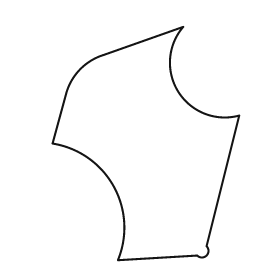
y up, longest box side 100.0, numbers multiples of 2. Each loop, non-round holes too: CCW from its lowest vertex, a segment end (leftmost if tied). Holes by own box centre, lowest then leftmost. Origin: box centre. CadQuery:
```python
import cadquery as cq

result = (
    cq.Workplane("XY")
    .moveTo(-12.0, -50.0)
    .lineTo(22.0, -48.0)
    .threePointArc((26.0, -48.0), (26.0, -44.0))
    .lineTo(40.0, 12.0)
    .threePointArc((14.0, 22.0), (16.0, 50.0))
    .lineTo(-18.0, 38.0)
    .threePointArc((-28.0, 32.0), (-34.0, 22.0))
    .lineTo(-40.0, 0.0)
    .threePointArc((-14.0, -18.0), (-12.0, -50.0))
    .close()
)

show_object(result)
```